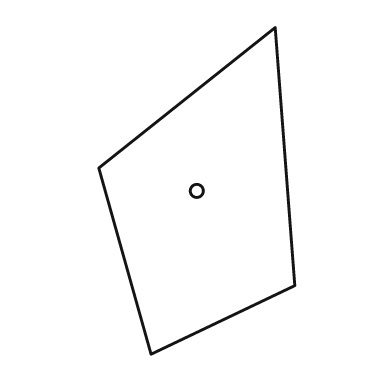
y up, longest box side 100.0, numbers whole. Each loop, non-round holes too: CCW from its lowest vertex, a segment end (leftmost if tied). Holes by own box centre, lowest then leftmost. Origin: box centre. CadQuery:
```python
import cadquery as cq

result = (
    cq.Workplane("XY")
    .moveTo(-14.0, -50.0)
    .lineTo(30.0, -29.0)
    .lineTo(24.0, 50.0)
    .lineTo(-30.0, 7.0)
    .close()
    .moveTo(0.0, 0.0)
    .circle(2.0)
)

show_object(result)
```